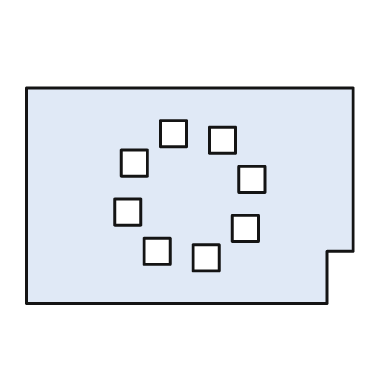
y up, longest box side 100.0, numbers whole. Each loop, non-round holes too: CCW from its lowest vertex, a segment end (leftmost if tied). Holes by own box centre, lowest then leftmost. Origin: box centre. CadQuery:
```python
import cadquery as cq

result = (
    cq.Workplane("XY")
    .moveTo(-50.0, -33.0)
    .lineTo(42.0, -33.0)
    .lineTo(42.0, -17.0)
    .lineTo(50.0, -17.0)
    .lineTo(50.0, 33.0)
    .lineTo(-50.0, 33.0)
    .close()
    .moveTo(1.0, -23.0)
    .lineTo(9.0, -23.0)
    .lineTo(9.0, -15.0)
    .lineTo(1.0, -15.0)
    .close()
    .moveTo(-14.0, -21.0)
    .lineTo(-6.0, -21.0)
    .lineTo(-6.0, -13.0)
    .lineTo(-14.0, -13.0)
    .close()
    .moveTo(13.0, -14.0)
    .lineTo(21.0, -14.0)
    .lineTo(21.0, -6.0)
    .lineTo(13.0, -6.0)
    .close()
    .moveTo(-23.0, -9.0)
    .lineTo(-15.0, -9.0)
    .lineTo(-15.0, -1.0)
    .lineTo(-23.0, -1.0)
    .close()
    .moveTo(15.0, 1.0)
    .lineTo(23.0, 1.0)
    .lineTo(23.0, 9.0)
    .lineTo(15.0, 9.0)
    .close()
    .moveTo(-21.0, 6.0)
    .lineTo(-13.0, 6.0)
    .lineTo(-13.0, 14.0)
    .lineTo(-21.0, 14.0)
    .close()
    .moveTo(6.0, 13.0)
    .lineTo(14.0, 13.0)
    .lineTo(14.0, 21.0)
    .lineTo(6.0, 21.0)
    .close()
    .moveTo(-9.0, 15.0)
    .lineTo(-1.0, 15.0)
    .lineTo(-1.0, 23.0)
    .lineTo(-9.0, 23.0)
    .close()
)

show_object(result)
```